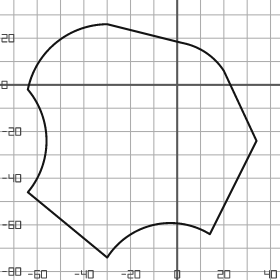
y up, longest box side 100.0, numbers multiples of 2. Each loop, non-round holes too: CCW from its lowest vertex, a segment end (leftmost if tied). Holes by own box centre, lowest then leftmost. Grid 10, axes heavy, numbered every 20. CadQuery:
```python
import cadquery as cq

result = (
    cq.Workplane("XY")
    .moveTo(-30.0, -74.0)
    .threePointArc((-10.0, -60.0), (14.0, -64.0))
    .lineTo(34.0, -24.0)
    .lineTo(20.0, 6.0)
    .threePointArc((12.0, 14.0), (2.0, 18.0))
    .lineTo(-30.0, 26.0)
    .threePointArc((-52.0, 18.0), (-64.0, -2.0))
    .threePointArc((-56.0, -24.0), (-64.0, -46.0))
    .close()
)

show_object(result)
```